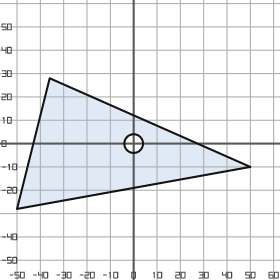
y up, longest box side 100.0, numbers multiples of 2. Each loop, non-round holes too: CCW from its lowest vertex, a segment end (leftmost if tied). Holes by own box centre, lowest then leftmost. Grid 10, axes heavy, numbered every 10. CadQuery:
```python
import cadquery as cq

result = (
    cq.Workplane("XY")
    .moveTo(-50.0, -28.0)
    .lineTo(50.0, -10.0)
    .lineTo(-36.0, 28.0)
    .close()
    .moveTo(0.0, 0.0)
    .circle(4.0)
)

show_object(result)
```